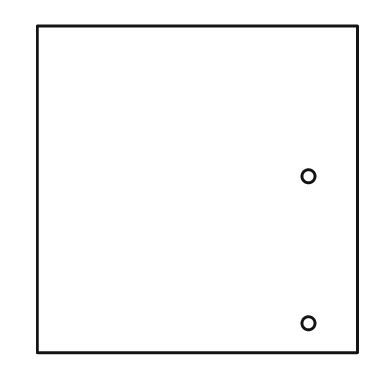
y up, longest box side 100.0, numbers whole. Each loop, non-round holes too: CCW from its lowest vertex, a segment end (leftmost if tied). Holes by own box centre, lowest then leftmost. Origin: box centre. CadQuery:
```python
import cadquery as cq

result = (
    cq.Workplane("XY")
    .moveTo(-49.0, -50.0)
    .lineTo(49.0, -50.0)
    .lineTo(49.0, 50.0)
    .lineTo(-49.0, 50.0)
    .close()
    .moveTo(34.0, -41.0)
    .circle(2.0)
    .moveTo(34.0, 4.0)
    .circle(2.0)
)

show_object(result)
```